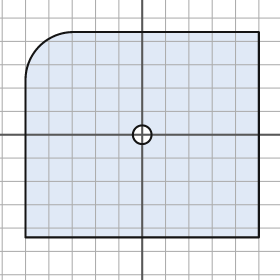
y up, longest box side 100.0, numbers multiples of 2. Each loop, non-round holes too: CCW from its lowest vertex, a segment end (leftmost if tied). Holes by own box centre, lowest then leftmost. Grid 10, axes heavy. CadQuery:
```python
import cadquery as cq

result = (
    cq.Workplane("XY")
    .moveTo(-50.0, -44.0)
    .lineTo(50.0, -44.0)
    .lineTo(50.0, 44.0)
    .lineTo(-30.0, 44.0)
    .threePointArc((-44.0, 38.0), (-50.0, 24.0))
    .close()
    .moveTo(0.0, 0.0)
    .circle(4.0)
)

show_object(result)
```